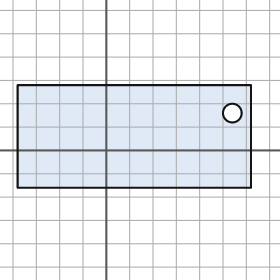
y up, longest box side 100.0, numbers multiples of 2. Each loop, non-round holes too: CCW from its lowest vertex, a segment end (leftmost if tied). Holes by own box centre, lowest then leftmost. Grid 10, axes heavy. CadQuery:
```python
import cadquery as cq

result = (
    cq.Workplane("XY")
    .moveTo(-38.0, -16.0)
    .lineTo(62.0, -16.0)
    .lineTo(62.0, 28.0)
    .lineTo(-38.0, 28.0)
    .close()
    .moveTo(54.0, 16.0)
    .circle(4.0)
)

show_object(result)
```